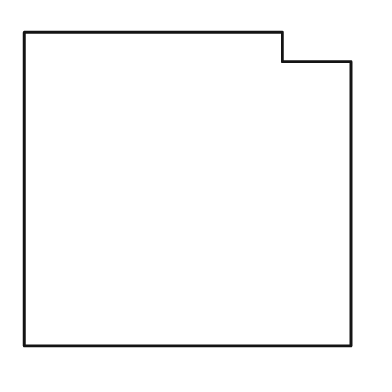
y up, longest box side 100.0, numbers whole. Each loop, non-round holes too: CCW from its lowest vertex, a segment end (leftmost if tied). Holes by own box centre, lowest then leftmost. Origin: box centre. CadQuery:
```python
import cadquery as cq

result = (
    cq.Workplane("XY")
    .moveTo(-50.0, -48.0)
    .lineTo(50.0, -48.0)
    .lineTo(50.0, 39.0)
    .lineTo(29.0, 39.0)
    .lineTo(29.0, 48.0)
    .lineTo(-50.0, 48.0)
    .close()
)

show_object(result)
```